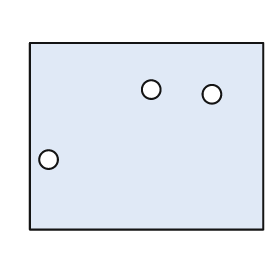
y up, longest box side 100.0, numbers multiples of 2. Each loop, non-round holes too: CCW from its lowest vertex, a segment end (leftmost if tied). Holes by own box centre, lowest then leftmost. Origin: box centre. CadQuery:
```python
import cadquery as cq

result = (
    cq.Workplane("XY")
    .moveTo(-50.0, -40.0)
    .lineTo(50.0, -40.0)
    .lineTo(50.0, 40.0)
    .lineTo(-50.0, 40.0)
    .close()
    .moveTo(-42.0, -10.0)
    .circle(4.0)
    .moveTo(28.0, 18.0)
    .circle(4.0)
    .moveTo(2.0, 20.0)
    .circle(4.0)
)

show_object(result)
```